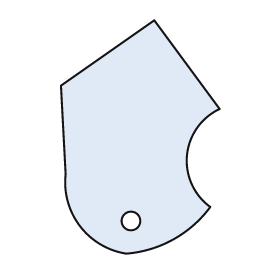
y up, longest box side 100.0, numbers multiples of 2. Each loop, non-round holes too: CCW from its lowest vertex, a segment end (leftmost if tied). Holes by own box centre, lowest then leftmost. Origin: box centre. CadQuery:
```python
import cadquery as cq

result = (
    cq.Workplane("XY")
    .moveTo(-6.0, -50.0)
    .threePointArc((14.0, -44.0), (30.0, -30.0))
    .threePointArc((20.0, -8.0), (34.0, 12.0))
    .lineTo(6.0, 50.0)
    .lineTo(-34.0, 22.0)
    .lineTo(-32.0, -16.0)
    .threePointArc((-26.0, -38.0), (-6.0, -50.0))
    .close()
    .moveTo(-4.0, -36.0)
    .circle(4.0)
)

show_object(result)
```